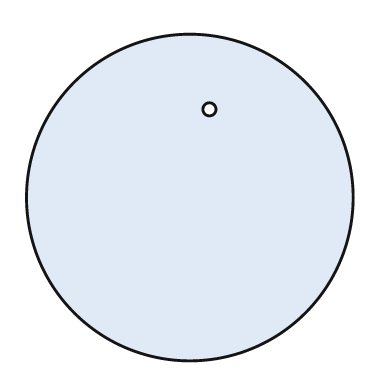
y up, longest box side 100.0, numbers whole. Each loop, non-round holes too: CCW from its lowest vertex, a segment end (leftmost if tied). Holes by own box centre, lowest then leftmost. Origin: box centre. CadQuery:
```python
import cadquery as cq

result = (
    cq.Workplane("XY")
    .moveTo(0.0, 0.0)
    .circle(50.0)
    .moveTo(6.0, 27.0)
    .circle(2.0)
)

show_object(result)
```